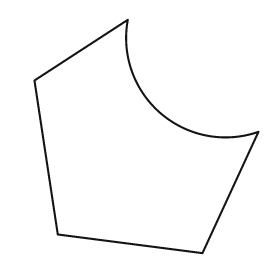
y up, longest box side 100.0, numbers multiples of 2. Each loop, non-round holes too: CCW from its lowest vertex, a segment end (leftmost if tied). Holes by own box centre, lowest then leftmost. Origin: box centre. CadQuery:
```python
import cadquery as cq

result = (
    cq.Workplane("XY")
    .moveTo(24.0, -50.0)
    .lineTo(48.0, 2.0)
    .threePointArc((6.0, 10.0), (-8.0, 50.0))
    .lineTo(-48.0, 24.0)
    .lineTo(-38.0, -42.0)
    .close()
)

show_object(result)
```